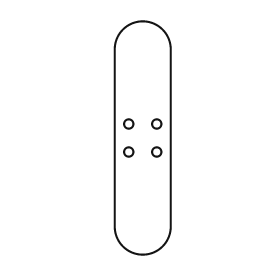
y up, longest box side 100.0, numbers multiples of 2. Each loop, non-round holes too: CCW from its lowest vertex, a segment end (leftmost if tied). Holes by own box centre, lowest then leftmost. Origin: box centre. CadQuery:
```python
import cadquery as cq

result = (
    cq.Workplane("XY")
    .moveTo(-12.0, -38.0)
    .threePointArc((0.0, -50.0), (12.0, -38.0))
    .lineTo(12.0, 38.0)
    .threePointArc((0.0, 50.0), (-12.0, 38.0))
    .close()
    .moveTo(-6.0, -6.0)
    .circle(2.0)
    .moveTo(6.0, -6.0)
    .circle(2.0)
    .moveTo(-6.0, 6.0)
    .circle(2.0)
    .moveTo(6.0, 6.0)
    .circle(2.0)
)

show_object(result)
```